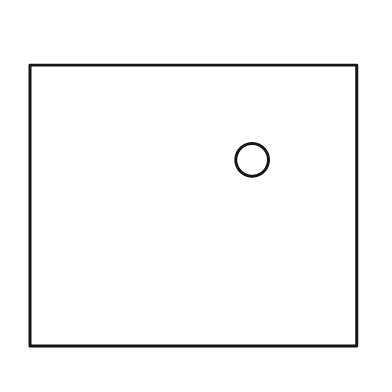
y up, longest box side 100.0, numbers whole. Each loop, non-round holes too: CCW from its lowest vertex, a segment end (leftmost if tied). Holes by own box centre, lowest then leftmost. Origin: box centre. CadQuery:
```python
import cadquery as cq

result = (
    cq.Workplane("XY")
    .moveTo(-50.0, -43.0)
    .lineTo(50.0, -43.0)
    .lineTo(50.0, 43.0)
    .lineTo(-50.0, 43.0)
    .close()
    .moveTo(18.0, 14.0)
    .circle(5.0)
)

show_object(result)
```